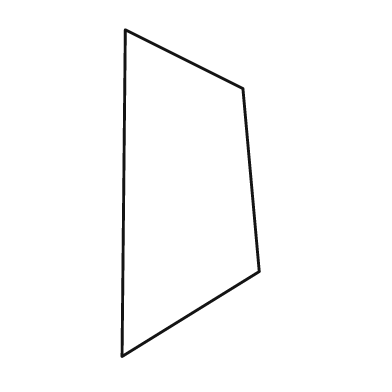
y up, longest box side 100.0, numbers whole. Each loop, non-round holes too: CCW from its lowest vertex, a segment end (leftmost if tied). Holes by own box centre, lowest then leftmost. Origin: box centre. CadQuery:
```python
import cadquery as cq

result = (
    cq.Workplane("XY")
    .moveTo(-21.0, -50.0)
    .lineTo(21.0, -24.0)
    .lineTo(16.0, 32.0)
    .lineTo(-20.0, 50.0)
    .close()
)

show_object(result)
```